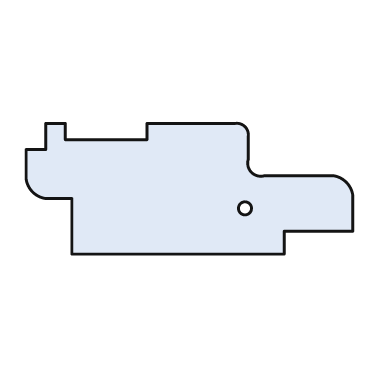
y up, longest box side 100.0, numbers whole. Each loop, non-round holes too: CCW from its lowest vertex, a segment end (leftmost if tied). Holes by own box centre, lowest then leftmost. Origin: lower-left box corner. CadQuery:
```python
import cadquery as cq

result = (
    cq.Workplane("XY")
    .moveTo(14.0, 0.0)
    .lineTo(79.0, 0.0)
    .lineTo(79.0, 7.0)
    .lineTo(100.0, 7.0)
    .lineTo(100.0, 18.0)
    .threePointArc((98.0, 22.0), (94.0, 24.0))
    .lineTo(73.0, 24.0)
    .threePointArc((69.0, 25.0), (68.0, 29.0))
    .lineTo(68.0, 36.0)
    .threePointArc((67.0, 39.0), (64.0, 40.0))
    .lineTo(37.0, 40.0)
    .lineTo(37.0, 35.0)
    .lineTo(12.0, 35.0)
    .lineTo(12.0, 40.0)
    .lineTo(6.0, 40.0)
    .lineTo(6.0, 32.0)
    .lineTo(0.0, 32.0)
    .lineTo(0.0, 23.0)
    .threePointArc((2.0, 19.0), (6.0, 17.0))
    .lineTo(14.0, 17.0)
    .close()
    .moveTo(67.0, 14.0)
    .circle(2.0)
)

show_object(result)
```